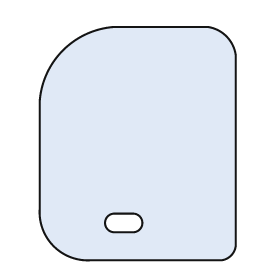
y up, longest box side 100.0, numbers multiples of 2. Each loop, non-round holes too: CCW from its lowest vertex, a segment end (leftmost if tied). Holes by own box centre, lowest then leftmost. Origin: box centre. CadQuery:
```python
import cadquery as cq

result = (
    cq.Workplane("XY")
    .moveTo(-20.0, -50.0)
    .lineTo(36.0, -50.0)
    .threePointArc((40.0, -48.0), (42.0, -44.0))
    .lineTo(42.0, 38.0)
    .threePointArc((38.0, 46.0), (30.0, 50.0))
    .lineTo(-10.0, 50.0)
    .threePointArc((-32.0, 40.0), (-42.0, 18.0))
    .lineTo(-42.0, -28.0)
    .threePointArc((-36.0, -44.0), (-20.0, -50.0))
    .close()
    .moveTo(-10.0, -38.0)
    .lineTo(-2.0, -38.0)
    .threePointArc((2.0, -34.0), (-2.0, -30.0))
    .lineTo(-10.0, -30.0)
    .threePointArc((-14.0, -34.0), (-10.0, -38.0))
    .close()
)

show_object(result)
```